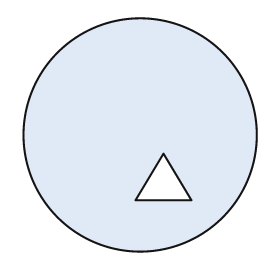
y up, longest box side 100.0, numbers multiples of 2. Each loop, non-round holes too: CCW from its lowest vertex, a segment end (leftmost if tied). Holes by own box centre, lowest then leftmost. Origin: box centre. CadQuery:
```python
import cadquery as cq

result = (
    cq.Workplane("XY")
    .moveTo(0.0, 0.0)
    .circle(50.0)
    .moveTo(-2.0, -28.0)
    .lineTo(22.0, -28.0)
    .lineTo(10.0, -8.0)
    .close()
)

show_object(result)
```